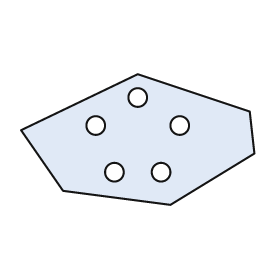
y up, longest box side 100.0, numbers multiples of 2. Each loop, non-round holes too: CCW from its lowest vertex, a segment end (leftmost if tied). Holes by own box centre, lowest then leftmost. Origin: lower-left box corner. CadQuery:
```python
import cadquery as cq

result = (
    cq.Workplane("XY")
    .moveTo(64.0, 0.0)
    .lineTo(100.0, 22.0)
    .lineTo(98.0, 40.0)
    .lineTo(50.0, 56.0)
    .lineTo(0.0, 32.0)
    .lineTo(18.0, 6.0)
    .close()
    .moveTo(40.0, 14.0)
    .circle(4.0)
    .moveTo(60.0, 14.0)
    .circle(4.0)
    .moveTo(32.0, 34.0)
    .circle(4.0)
    .moveTo(68.0, 34.0)
    .circle(4.0)
    .moveTo(50.0, 46.0)
    .circle(4.0)
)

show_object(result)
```